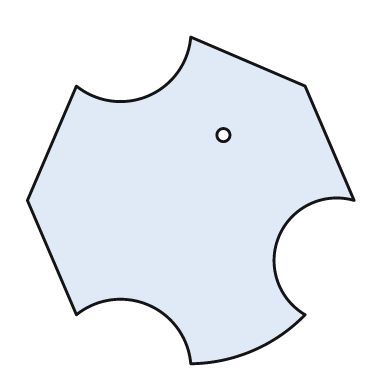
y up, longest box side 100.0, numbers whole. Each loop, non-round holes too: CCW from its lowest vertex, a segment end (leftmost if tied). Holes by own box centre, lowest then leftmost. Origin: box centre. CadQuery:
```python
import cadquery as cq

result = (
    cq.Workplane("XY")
    .moveTo(0.0, -50.0)
    .threePointArc((19.0, -46.0), (35.0, -35.0))
    .threePointArc((27.0, -11.0), (50.0, 0.0))
    .lineTo(35.0, 35.0)
    .lineTo(0.0, 50.0)
    .threePointArc((-13.0, 32.0), (-35.0, 35.0))
    .lineTo(-50.0, 0.0)
    .lineTo(-35.0, -35.0)
    .threePointArc((-13.0, -32.0), (0.0, -50.0))
    .close()
    .moveTo(10.0, 20.0)
    .circle(2.0)
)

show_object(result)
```